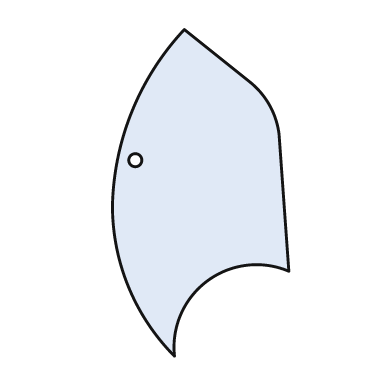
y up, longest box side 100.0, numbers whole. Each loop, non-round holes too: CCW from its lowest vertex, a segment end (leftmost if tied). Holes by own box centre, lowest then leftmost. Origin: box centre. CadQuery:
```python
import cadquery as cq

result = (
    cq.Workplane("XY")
    .moveTo(-8.0, -50.0)
    .threePointArc((2.0, -27.0), (27.0, -24.0))
    .lineTo(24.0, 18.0)
    .threePointArc((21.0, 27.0), (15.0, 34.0))
    .lineTo(-5.0, 50.0)
    .threePointArc((-21.0, 25.0), (-27.0, -4.0))
    .threePointArc((-22.0, -29.0), (-8.0, -50.0))
    .close()
    .moveTo(-20.0, 10.0)
    .circle(2.0)
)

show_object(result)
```